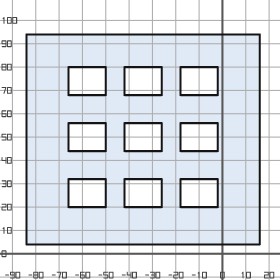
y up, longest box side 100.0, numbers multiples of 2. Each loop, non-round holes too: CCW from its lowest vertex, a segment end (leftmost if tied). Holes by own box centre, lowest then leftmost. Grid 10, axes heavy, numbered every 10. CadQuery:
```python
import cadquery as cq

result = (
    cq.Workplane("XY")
    .moveTo(-84.0, 4.0)
    .lineTo(16.0, 4.0)
    .lineTo(16.0, 94.0)
    .lineTo(-84.0, 94.0)
    .close()
    .moveTo(-66.0, 20.0)
    .lineTo(-50.0, 20.0)
    .lineTo(-50.0, 32.0)
    .lineTo(-66.0, 32.0)
    .close()
    .moveTo(-42.0, 20.0)
    .lineTo(-26.0, 20.0)
    .lineTo(-26.0, 32.0)
    .lineTo(-42.0, 32.0)
    .close()
    .moveTo(-18.0, 20.0)
    .lineTo(-2.0, 20.0)
    .lineTo(-2.0, 32.0)
    .lineTo(-18.0, 32.0)
    .close()
    .moveTo(-66.0, 44.0)
    .lineTo(-50.0, 44.0)
    .lineTo(-50.0, 56.0)
    .lineTo(-66.0, 56.0)
    .close()
    .moveTo(-42.0, 44.0)
    .lineTo(-26.0, 44.0)
    .lineTo(-26.0, 56.0)
    .lineTo(-42.0, 56.0)
    .close()
    .moveTo(-18.0, 44.0)
    .lineTo(-2.0, 44.0)
    .lineTo(-2.0, 56.0)
    .lineTo(-18.0, 56.0)
    .close()
    .moveTo(-66.0, 68.0)
    .lineTo(-50.0, 68.0)
    .lineTo(-50.0, 80.0)
    .lineTo(-66.0, 80.0)
    .close()
    .moveTo(-42.0, 68.0)
    .lineTo(-26.0, 68.0)
    .lineTo(-26.0, 80.0)
    .lineTo(-42.0, 80.0)
    .close()
    .moveTo(-18.0, 68.0)
    .lineTo(-2.0, 68.0)
    .lineTo(-2.0, 80.0)
    .lineTo(-18.0, 80.0)
    .close()
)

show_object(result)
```